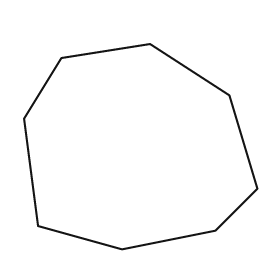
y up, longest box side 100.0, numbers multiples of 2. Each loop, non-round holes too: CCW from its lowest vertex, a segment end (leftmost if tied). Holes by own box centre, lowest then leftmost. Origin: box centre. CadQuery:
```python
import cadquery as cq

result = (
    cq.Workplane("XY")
    .moveTo(-8.0, -44.0)
    .lineTo(32.0, -36.0)
    .lineTo(50.0, -18.0)
    .lineTo(38.0, 22.0)
    .lineTo(4.0, 44.0)
    .lineTo(-34.0, 38.0)
    .lineTo(-50.0, 12.0)
    .lineTo(-44.0, -34.0)
    .close()
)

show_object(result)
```